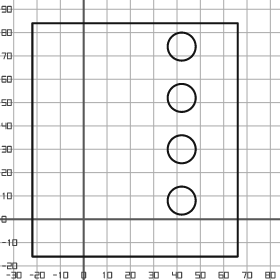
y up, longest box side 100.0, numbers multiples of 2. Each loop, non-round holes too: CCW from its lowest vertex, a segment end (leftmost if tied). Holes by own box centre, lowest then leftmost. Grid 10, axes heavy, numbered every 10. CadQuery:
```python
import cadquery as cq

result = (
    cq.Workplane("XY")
    .moveTo(-22.0, -16.0)
    .lineTo(66.0, -16.0)
    .lineTo(66.0, 84.0)
    .lineTo(-22.0, 84.0)
    .close()
    .moveTo(42.0, 8.0)
    .circle(6.0)
    .moveTo(42.0, 30.0)
    .circle(6.0)
    .moveTo(42.0, 52.0)
    .circle(6.0)
    .moveTo(42.0, 74.0)
    .circle(6.0)
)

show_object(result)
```